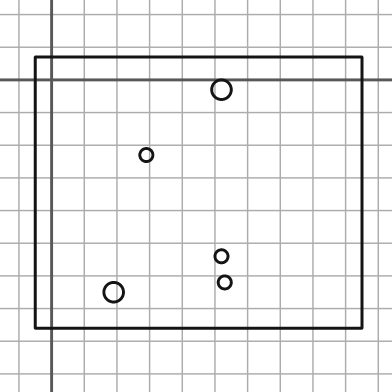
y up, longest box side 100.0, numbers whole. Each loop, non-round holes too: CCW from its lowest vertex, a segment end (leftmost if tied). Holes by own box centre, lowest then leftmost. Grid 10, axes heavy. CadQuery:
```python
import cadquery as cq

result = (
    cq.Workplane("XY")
    .moveTo(-5.0, -76.0)
    .lineTo(95.0, -76.0)
    .lineTo(95.0, 7.0)
    .lineTo(-5.0, 7.0)
    .close()
    .moveTo(19.0, -65.0)
    .circle(3.0)
    .moveTo(53.0, -62.0)
    .circle(2.0)
    .moveTo(52.0, -54.0)
    .circle(2.0)
    .moveTo(29.0, -23.0)
    .circle(2.0)
    .moveTo(52.0, -3.0)
    .circle(3.0)
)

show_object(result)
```